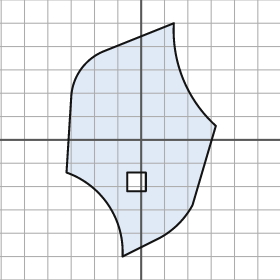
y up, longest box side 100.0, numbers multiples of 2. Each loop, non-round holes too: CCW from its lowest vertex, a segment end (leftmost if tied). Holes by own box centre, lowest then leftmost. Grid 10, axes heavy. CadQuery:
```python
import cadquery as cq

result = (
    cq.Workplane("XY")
    .moveTo(-8.0, -50.0)
    .lineTo(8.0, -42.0)
    .threePointArc((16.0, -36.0), (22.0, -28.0))
    .lineTo(32.0, 6.0)
    .threePointArc((18.0, 26.0), (14.0, 50.0))
    .lineTo(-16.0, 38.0)
    .threePointArc((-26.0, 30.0), (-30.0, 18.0))
    .lineTo(-32.0, -14.0)
    .threePointArc((-14.0, -28.0), (-8.0, -50.0))
    .close()
    .moveTo(-6.0, -22.0)
    .lineTo(2.0, -22.0)
    .lineTo(2.0, -14.0)
    .lineTo(-6.0, -14.0)
    .close()
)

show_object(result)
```